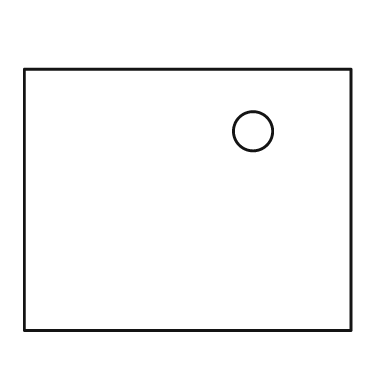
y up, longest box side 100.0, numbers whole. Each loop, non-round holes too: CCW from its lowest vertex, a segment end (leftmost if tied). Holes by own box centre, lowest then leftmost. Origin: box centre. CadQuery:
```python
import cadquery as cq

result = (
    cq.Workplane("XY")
    .moveTo(-50.0, -40.0)
    .lineTo(50.0, -40.0)
    .lineTo(50.0, 40.0)
    .lineTo(-50.0, 40.0)
    .close()
    .moveTo(20.0, 21.0)
    .circle(6.0)
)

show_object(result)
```